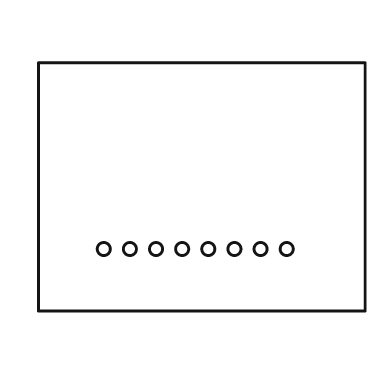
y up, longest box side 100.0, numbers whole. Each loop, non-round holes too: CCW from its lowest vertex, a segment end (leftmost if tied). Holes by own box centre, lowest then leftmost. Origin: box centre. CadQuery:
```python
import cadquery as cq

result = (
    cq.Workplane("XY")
    .moveTo(-50.0, -38.0)
    .lineTo(50.0, -38.0)
    .lineTo(50.0, 38.0)
    .lineTo(-50.0, 38.0)
    .close()
    .moveTo(-30.0, -19.0)
    .circle(2.0)
    .moveTo(-22.0, -19.0)
    .circle(2.0)
    .moveTo(-14.0, -19.0)
    .circle(2.0)
    .moveTo(-6.0, -19.0)
    .circle(2.0)
    .moveTo(2.0, -19.0)
    .circle(2.0)
    .moveTo(10.0, -19.0)
    .circle(2.0)
    .moveTo(18.0, -19.0)
    .circle(2.0)
    .moveTo(26.0, -19.0)
    .circle(2.0)
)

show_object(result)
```